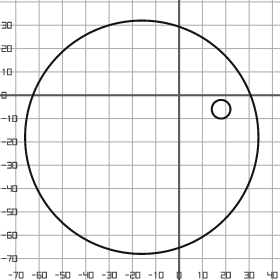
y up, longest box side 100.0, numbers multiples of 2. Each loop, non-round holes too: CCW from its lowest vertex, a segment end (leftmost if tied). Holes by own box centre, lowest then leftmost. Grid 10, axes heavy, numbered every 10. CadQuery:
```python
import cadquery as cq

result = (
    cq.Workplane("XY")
    .moveTo(-16.0, -18.0)
    .circle(50.0)
    .moveTo(18.0, -6.0)
    .circle(4.0)
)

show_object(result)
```